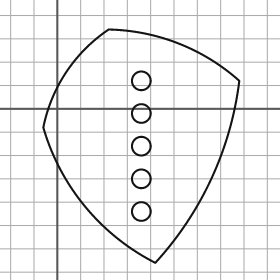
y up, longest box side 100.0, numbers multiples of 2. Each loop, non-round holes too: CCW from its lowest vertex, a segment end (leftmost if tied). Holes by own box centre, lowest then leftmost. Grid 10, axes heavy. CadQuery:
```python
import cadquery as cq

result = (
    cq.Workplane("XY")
    .moveTo(42.0, -66.0)
    .threePointArc((66.0, -30.0), (78.0, 12.0))
    .threePointArc((52.0, 28.0), (22.0, 34.0))
    .threePointArc((4.0, 16.0), (-6.0, -8.0))
    .threePointArc((12.0, -42.0), (42.0, -66.0))
    .close()
    .moveTo(36.0, -44.0)
    .circle(4.0)
    .moveTo(36.0, -30.0)
    .circle(4.0)
    .moveTo(36.0, -16.0)
    .circle(4.0)
    .moveTo(36.0, -2.0)
    .circle(4.0)
    .moveTo(36.0, 12.0)
    .circle(4.0)
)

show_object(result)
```